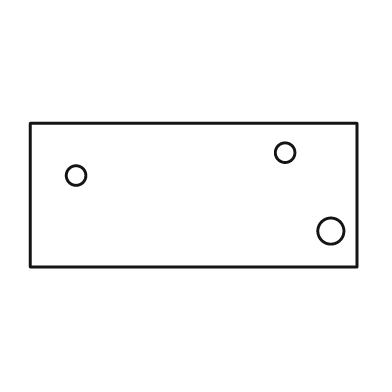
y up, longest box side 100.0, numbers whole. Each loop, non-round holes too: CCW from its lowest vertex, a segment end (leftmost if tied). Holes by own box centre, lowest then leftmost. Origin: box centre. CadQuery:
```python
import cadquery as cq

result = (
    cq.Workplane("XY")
    .moveTo(-50.0, -22.0)
    .lineTo(50.0, -22.0)
    .lineTo(50.0, 22.0)
    .lineTo(-50.0, 22.0)
    .close()
    .moveTo(42.0, -11.0)
    .circle(4.0)
    .moveTo(-36.0, 6.0)
    .circle(3.0)
    .moveTo(28.0, 13.0)
    .circle(3.0)
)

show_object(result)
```